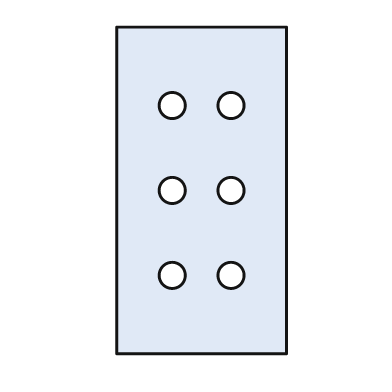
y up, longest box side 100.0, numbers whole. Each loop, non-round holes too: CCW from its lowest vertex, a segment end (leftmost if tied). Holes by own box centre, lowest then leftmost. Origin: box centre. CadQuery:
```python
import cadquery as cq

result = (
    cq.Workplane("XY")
    .moveTo(-26.0, -50.0)
    .lineTo(26.0, -50.0)
    .lineTo(26.0, 50.0)
    .lineTo(-26.0, 50.0)
    .close()
    .moveTo(-9.0, -26.0)
    .circle(4.0)
    .moveTo(9.0, -26.0)
    .circle(4.0)
    .moveTo(-9.0, 0.0)
    .circle(4.0)
    .moveTo(9.0, 0.0)
    .circle(4.0)
    .moveTo(-9.0, 26.0)
    .circle(4.0)
    .moveTo(9.0, 26.0)
    .circle(4.0)
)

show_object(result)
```